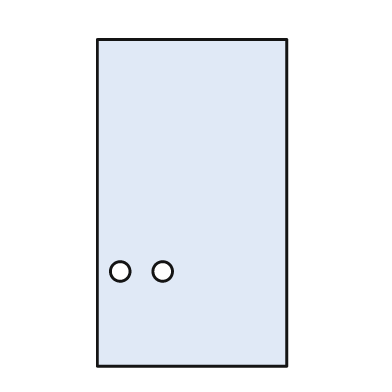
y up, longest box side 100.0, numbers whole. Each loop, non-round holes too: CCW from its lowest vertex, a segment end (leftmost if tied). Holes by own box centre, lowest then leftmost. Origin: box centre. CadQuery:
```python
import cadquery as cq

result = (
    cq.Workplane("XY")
    .moveTo(-29.0, -50.0)
    .lineTo(29.0, -50.0)
    .lineTo(29.0, 50.0)
    .lineTo(-29.0, 50.0)
    .close()
    .moveTo(-22.0, -21.0)
    .circle(3.0)
    .moveTo(-9.0, -21.0)
    .circle(3.0)
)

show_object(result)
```